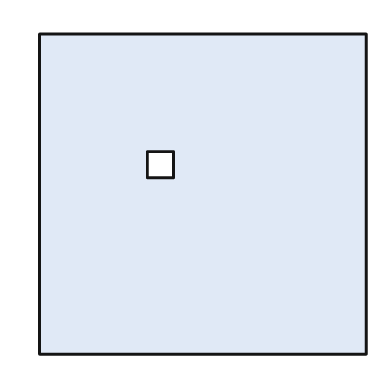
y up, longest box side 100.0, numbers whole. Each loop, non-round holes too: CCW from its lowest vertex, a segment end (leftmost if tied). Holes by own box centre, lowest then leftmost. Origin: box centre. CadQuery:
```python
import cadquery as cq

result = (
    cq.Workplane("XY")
    .moveTo(-50.0, -49.0)
    .lineTo(50.0, -49.0)
    .lineTo(50.0, 49.0)
    .lineTo(-50.0, 49.0)
    .close()
    .moveTo(-17.0, 5.0)
    .lineTo(-9.0, 5.0)
    .lineTo(-9.0, 13.0)
    .lineTo(-17.0, 13.0)
    .close()
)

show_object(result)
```